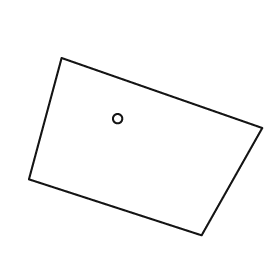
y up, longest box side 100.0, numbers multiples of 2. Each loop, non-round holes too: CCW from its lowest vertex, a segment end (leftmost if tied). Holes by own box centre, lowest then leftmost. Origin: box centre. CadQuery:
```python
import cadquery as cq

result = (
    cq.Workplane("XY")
    .moveTo(24.0, -38.0)
    .lineTo(50.0, 8.0)
    .lineTo(-36.0, 38.0)
    .lineTo(-50.0, -14.0)
    .close()
    .moveTo(-12.0, 12.0)
    .circle(2.0)
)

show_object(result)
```